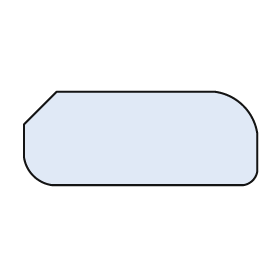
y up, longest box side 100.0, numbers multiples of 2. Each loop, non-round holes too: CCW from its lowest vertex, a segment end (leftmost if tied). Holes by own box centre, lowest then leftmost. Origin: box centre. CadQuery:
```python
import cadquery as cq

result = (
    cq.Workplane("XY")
    .moveTo(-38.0, -20.0)
    .lineTo(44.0, -20.0)
    .threePointArc((48.0, -18.0), (50.0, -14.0))
    .lineTo(50.0, 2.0)
    .threePointArc((44.0, 14.0), (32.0, 20.0))
    .lineTo(-36.0, 20.0)
    .lineTo(-50.0, 6.0)
    .lineTo(-50.0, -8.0)
    .threePointArc((-46.0, -16.0), (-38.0, -20.0))
    .close()
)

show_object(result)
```